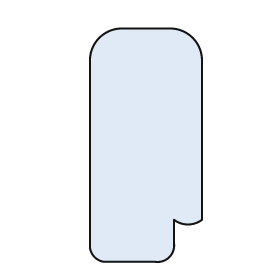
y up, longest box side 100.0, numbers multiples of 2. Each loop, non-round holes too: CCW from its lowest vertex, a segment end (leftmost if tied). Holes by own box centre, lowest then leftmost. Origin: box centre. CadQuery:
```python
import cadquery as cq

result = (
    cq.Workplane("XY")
    .moveTo(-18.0, -50.0)
    .lineTo(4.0, -50.0)
    .threePointArc((10.0, -48.0), (12.0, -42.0))
    .lineTo(12.0, -32.0)
    .threePointArc((18.0, -34.0), (24.0, -32.0))
    .lineTo(24.0, 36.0)
    .threePointArc((20.0, 46.0), (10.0, 50.0))
    .lineTo(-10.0, 50.0)
    .threePointArc((-20.0, 46.0), (-24.0, 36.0))
    .lineTo(-24.0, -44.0)
    .threePointArc((-22.0, -48.0), (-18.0, -50.0))
    .close()
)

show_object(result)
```